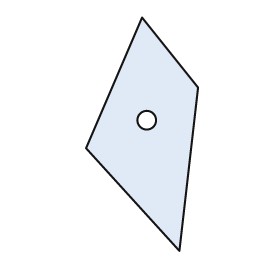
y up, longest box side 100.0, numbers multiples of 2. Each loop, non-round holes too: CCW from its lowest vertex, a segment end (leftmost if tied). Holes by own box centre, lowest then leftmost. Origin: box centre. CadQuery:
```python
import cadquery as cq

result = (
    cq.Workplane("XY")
    .moveTo(16.0, -50.0)
    .lineTo(24.0, 20.0)
    .lineTo(0.0, 50.0)
    .lineTo(-24.0, -6.0)
    .close()
    .moveTo(2.0, 6.0)
    .circle(4.0)
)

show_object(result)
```